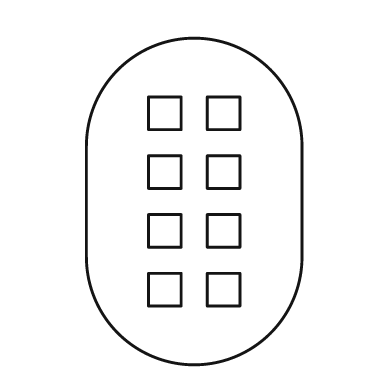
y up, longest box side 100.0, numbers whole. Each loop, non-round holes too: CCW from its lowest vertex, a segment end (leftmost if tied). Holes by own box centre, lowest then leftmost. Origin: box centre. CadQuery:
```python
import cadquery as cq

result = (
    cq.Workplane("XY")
    .moveTo(-33.0, -17.0)
    .threePointArc((0.0, -50.0), (33.0, -17.0))
    .lineTo(33.0, 17.0)
    .threePointArc((0.0, 50.0), (-33.0, 17.0))
    .close()
    .moveTo(-14.0, -32.0)
    .lineTo(-4.0, -32.0)
    .lineTo(-4.0, -22.0)
    .lineTo(-14.0, -22.0)
    .close()
    .moveTo(4.0, -32.0)
    .lineTo(14.0, -32.0)
    .lineTo(14.0, -22.0)
    .lineTo(4.0, -22.0)
    .close()
    .moveTo(-14.0, -14.0)
    .lineTo(-4.0, -14.0)
    .lineTo(-4.0, -4.0)
    .lineTo(-14.0, -4.0)
    .close()
    .moveTo(4.0, -14.0)
    .lineTo(14.0, -14.0)
    .lineTo(14.0, -4.0)
    .lineTo(4.0, -4.0)
    .close()
    .moveTo(-14.0, 4.0)
    .lineTo(-4.0, 4.0)
    .lineTo(-4.0, 14.0)
    .lineTo(-14.0, 14.0)
    .close()
    .moveTo(4.0, 4.0)
    .lineTo(14.0, 4.0)
    .lineTo(14.0, 14.0)
    .lineTo(4.0, 14.0)
    .close()
    .moveTo(-14.0, 22.0)
    .lineTo(-4.0, 22.0)
    .lineTo(-4.0, 32.0)
    .lineTo(-14.0, 32.0)
    .close()
    .moveTo(4.0, 22.0)
    .lineTo(14.0, 22.0)
    .lineTo(14.0, 32.0)
    .lineTo(4.0, 32.0)
    .close()
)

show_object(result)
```